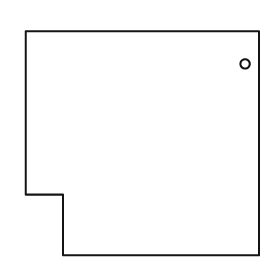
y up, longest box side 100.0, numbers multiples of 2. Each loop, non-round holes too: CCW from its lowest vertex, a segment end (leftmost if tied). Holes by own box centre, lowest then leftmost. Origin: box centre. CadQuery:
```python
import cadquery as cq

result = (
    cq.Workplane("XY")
    .moveTo(-34.0, -48.0)
    .lineTo(50.0, -48.0)
    .lineTo(50.0, 48.0)
    .lineTo(-50.0, 48.0)
    .lineTo(-50.0, -22.0)
    .lineTo(-34.0, -22.0)
    .close()
    .moveTo(44.0, 34.0)
    .circle(2.0)
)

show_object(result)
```